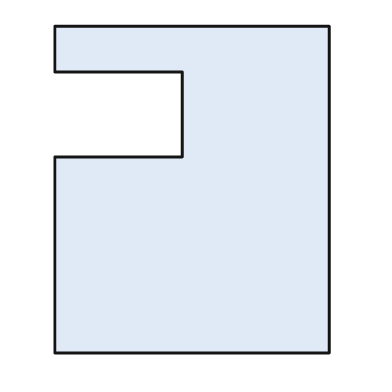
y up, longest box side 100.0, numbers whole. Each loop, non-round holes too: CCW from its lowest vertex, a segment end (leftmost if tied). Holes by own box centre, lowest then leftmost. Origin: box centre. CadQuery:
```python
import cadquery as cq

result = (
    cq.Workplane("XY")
    .moveTo(-42.0, -50.0)
    .lineTo(42.0, -50.0)
    .lineTo(42.0, 50.0)
    .lineTo(-42.0, 50.0)
    .lineTo(-42.0, 36.0)
    .lineTo(-3.0, 36.0)
    .lineTo(-3.0, 10.0)
    .lineTo(-42.0, 10.0)
    .close()
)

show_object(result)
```